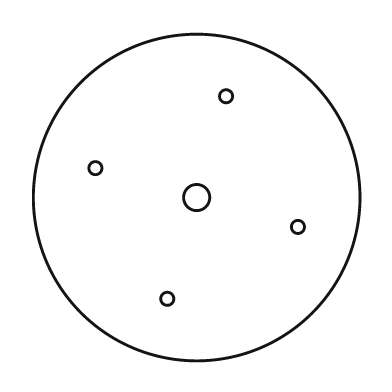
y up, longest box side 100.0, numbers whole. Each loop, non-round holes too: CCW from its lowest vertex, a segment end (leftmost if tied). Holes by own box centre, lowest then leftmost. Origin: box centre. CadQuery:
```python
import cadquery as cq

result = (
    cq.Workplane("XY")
    .moveTo(0.0, 0.0)
    .circle(50.0)
    .moveTo(-9.0, -31.0)
    .circle(2.0)
    .moveTo(31.0, -9.0)
    .circle(2.0)
    .moveTo(0.0, 0.0)
    .circle(4.0)
    .moveTo(-31.0, 9.0)
    .circle(2.0)
    .moveTo(9.0, 31.0)
    .circle(2.0)
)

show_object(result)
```